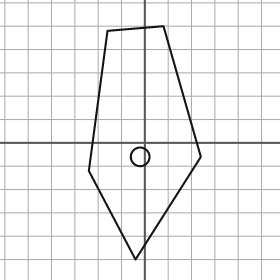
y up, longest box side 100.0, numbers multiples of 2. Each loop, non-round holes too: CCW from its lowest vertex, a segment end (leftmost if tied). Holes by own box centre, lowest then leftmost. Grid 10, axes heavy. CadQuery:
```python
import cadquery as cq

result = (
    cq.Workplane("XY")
    .moveTo(-4.0, -50.0)
    .lineTo(24.0, -6.0)
    .lineTo(8.0, 50.0)
    .lineTo(-16.0, 48.0)
    .lineTo(-24.0, -12.0)
    .close()
    .moveTo(-2.0, -6.0)
    .circle(4.0)
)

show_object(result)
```